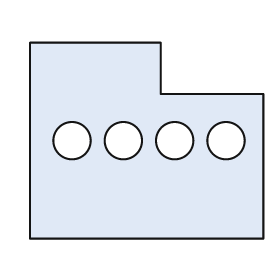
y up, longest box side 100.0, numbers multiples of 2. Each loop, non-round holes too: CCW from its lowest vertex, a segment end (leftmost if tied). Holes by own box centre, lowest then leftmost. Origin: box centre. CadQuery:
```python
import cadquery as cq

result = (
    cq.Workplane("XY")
    .moveTo(-50.0, -42.0)
    .lineTo(50.0, -42.0)
    .lineTo(50.0, 20.0)
    .lineTo(6.0, 20.0)
    .lineTo(6.0, 42.0)
    .lineTo(-50.0, 42.0)
    .close()
    .moveTo(-32.0, 0.0)
    .circle(8.0)
    .moveTo(-10.0, 0.0)
    .circle(8.0)
    .moveTo(12.0, 0.0)
    .circle(8.0)
    .moveTo(34.0, 0.0)
    .circle(8.0)
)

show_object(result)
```